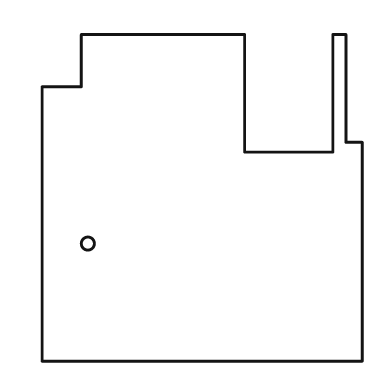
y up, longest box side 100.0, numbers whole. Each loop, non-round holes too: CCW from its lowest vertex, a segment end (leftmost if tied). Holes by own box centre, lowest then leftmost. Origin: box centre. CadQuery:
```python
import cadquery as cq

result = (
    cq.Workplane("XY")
    .moveTo(-49.0, -50.0)
    .lineTo(49.0, -50.0)
    .lineTo(49.0, 17.0)
    .lineTo(44.0, 17.0)
    .lineTo(44.0, 50.0)
    .lineTo(40.0, 50.0)
    .lineTo(40.0, 14.0)
    .lineTo(13.0, 14.0)
    .lineTo(13.0, 50.0)
    .lineTo(-37.0, 50.0)
    .lineTo(-37.0, 34.0)
    .lineTo(-49.0, 34.0)
    .close()
    .moveTo(-35.0, -14.0)
    .circle(2.0)
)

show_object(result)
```